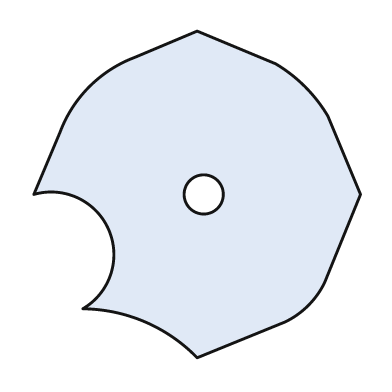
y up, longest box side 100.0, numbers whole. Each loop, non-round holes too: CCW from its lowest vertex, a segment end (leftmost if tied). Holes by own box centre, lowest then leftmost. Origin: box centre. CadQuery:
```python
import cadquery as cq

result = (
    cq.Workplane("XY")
    .moveTo(0.0, -50.0)
    .lineTo(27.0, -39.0)
    .threePointArc((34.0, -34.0), (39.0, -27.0))
    .lineTo(50.0, 0.0)
    .lineTo(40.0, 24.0)
    .threePointArc((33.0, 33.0), (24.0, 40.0))
    .lineTo(0.0, 50.0)
    .lineTo(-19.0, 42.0)
    .threePointArc((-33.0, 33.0), (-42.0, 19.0))
    .lineTo(-50.0, 0.0)
    .threePointArc((-27.0, -11.0), (-35.0, -35.0))
    .threePointArc((-16.0, -39.0), (0.0, -50.0))
    .close()
    .moveTo(2.0, 0.0)
    .circle(6.0)
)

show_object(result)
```